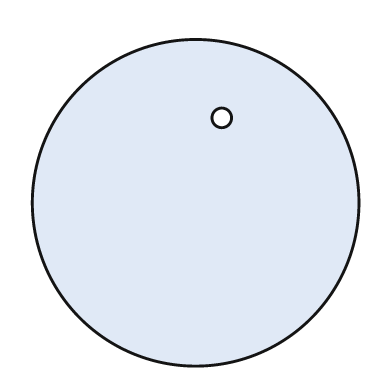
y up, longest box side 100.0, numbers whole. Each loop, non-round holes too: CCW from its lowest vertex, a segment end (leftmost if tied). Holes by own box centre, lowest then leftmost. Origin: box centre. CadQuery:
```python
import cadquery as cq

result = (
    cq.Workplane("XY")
    .moveTo(0.0, 0.0)
    .circle(50.0)
    .moveTo(8.0, 26.0)
    .circle(3.0)
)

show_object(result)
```